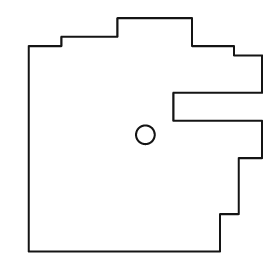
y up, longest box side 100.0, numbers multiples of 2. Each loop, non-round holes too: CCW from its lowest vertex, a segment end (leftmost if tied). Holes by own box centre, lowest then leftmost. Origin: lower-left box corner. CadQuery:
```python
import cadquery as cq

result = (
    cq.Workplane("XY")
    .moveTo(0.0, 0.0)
    .lineTo(82.0, 0.0)
    .lineTo(82.0, 16.0)
    .lineTo(90.0, 16.0)
    .lineTo(90.0, 40.0)
    .lineTo(100.0, 40.0)
    .lineTo(100.0, 56.0)
    .lineTo(62.0, 56.0)
    .lineTo(62.0, 68.0)
    .lineTo(100.0, 68.0)
    .lineTo(100.0, 84.0)
    .lineTo(88.0, 84.0)
    .lineTo(88.0, 88.0)
    .lineTo(70.0, 88.0)
    .lineTo(70.0, 100.0)
    .lineTo(38.0, 100.0)
    .lineTo(38.0, 92.0)
    .lineTo(14.0, 92.0)
    .lineTo(14.0, 88.0)
    .lineTo(0.0, 88.0)
    .close()
    .moveTo(50.0, 50.0)
    .circle(4.0)
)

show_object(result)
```